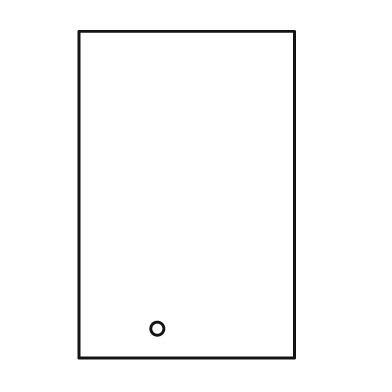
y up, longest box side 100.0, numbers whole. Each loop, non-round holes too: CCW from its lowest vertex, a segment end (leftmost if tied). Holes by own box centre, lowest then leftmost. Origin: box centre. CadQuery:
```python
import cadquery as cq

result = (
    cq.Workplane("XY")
    .moveTo(-33.0, -50.0)
    .lineTo(33.0, -50.0)
    .lineTo(33.0, 50.0)
    .lineTo(-33.0, 50.0)
    .close()
    .moveTo(-9.0, -41.0)
    .circle(2.0)
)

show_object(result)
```